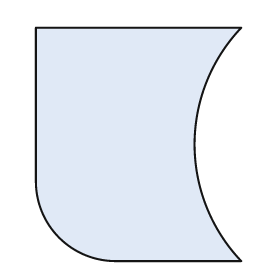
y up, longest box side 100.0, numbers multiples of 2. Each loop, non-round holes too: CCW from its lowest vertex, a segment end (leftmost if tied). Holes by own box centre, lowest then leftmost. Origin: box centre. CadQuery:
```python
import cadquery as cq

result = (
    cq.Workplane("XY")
    .moveTo(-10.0, -50.0)
    .lineTo(44.0, -50.0)
    .threePointArc((24.0, 0.0), (44.0, 50.0))
    .lineTo(-44.0, 50.0)
    .lineTo(-44.0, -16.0)
    .threePointArc((-34.0, -40.0), (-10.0, -50.0))
    .close()
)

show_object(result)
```